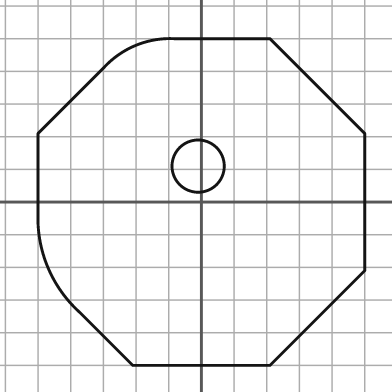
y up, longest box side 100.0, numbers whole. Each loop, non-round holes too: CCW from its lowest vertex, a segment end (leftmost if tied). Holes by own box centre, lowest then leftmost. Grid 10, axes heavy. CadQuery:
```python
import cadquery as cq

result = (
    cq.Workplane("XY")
    .moveTo(-21.0, -50.0)
    .lineTo(21.0, -50.0)
    .lineTo(50.0, -21.0)
    .lineTo(50.0, 21.0)
    .lineTo(21.0, 50.0)
    .lineTo(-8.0, 50.0)
    .threePointArc((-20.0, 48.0), (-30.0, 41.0))
    .lineTo(-50.0, 21.0)
    .lineTo(-50.0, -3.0)
    .threePointArc((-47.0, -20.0), (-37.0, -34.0))
    .close()
    .moveTo(-1.0, 11.0)
    .circle(8.0)
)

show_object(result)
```